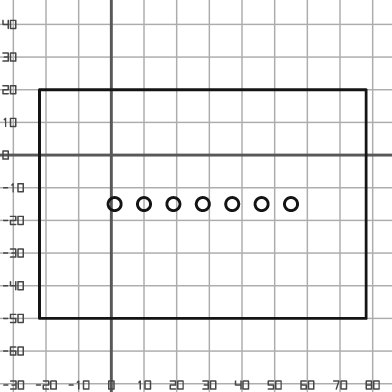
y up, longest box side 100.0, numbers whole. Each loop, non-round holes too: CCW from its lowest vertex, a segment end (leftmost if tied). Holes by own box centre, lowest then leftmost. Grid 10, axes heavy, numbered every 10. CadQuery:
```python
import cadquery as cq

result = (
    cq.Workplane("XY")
    .moveTo(-22.0, -50.0)
    .lineTo(78.0, -50.0)
    .lineTo(78.0, 20.0)
    .lineTo(-22.0, 20.0)
    .close()
    .moveTo(1.0, -15.0)
    .circle(2.0)
    .moveTo(10.0, -15.0)
    .circle(2.0)
    .moveTo(19.0, -15.0)
    .circle(2.0)
    .moveTo(28.0, -15.0)
    .circle(2.0)
    .moveTo(37.0, -15.0)
    .circle(2.0)
    .moveTo(46.0, -15.0)
    .circle(2.0)
    .moveTo(55.0, -15.0)
    .circle(2.0)
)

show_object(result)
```